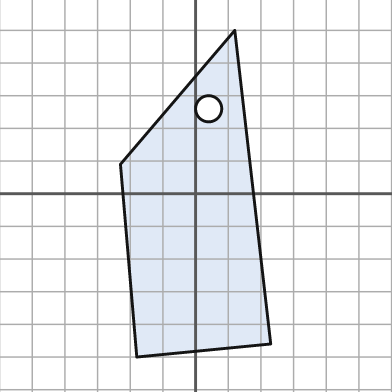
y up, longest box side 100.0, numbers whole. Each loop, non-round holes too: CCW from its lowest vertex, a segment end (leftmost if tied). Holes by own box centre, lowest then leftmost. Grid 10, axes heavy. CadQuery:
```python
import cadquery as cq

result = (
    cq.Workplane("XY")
    .moveTo(-18.0, -50.0)
    .lineTo(23.0, -46.0)
    .lineTo(12.0, 50.0)
    .lineTo(-23.0, 9.0)
    .close()
    .moveTo(4.0, 26.0)
    .circle(4.0)
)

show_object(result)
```